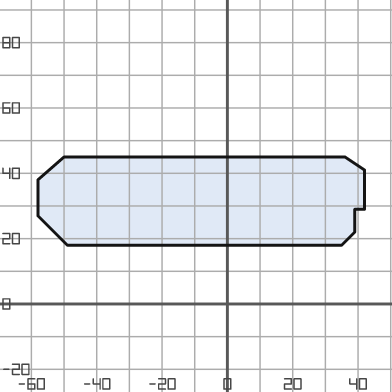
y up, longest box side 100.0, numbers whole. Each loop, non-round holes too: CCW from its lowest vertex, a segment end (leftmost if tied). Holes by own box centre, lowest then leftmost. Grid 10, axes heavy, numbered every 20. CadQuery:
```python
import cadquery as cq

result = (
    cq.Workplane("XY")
    .moveTo(-49.0, 18.0)
    .lineTo(35.0, 18.0)
    .lineTo(39.0, 22.0)
    .lineTo(39.0, 29.0)
    .lineTo(42.0, 29.0)
    .lineTo(42.0, 41.0)
    .lineTo(36.0, 45.0)
    .lineTo(-50.0, 45.0)
    .lineTo(-58.0, 38.0)
    .lineTo(-58.0, 27.0)
    .close()
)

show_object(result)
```